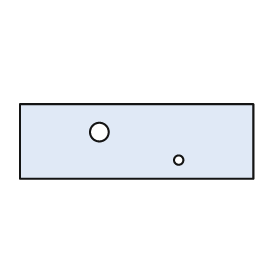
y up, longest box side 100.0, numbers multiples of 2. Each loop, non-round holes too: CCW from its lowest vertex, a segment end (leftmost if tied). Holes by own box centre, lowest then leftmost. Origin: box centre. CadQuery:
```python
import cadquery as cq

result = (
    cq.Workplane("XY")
    .moveTo(-50.0, -16.0)
    .lineTo(50.0, -16.0)
    .lineTo(50.0, 16.0)
    .lineTo(-50.0, 16.0)
    .close()
    .moveTo(18.0, -8.0)
    .circle(2.0)
    .moveTo(-16.0, 4.0)
    .circle(4.0)
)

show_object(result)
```